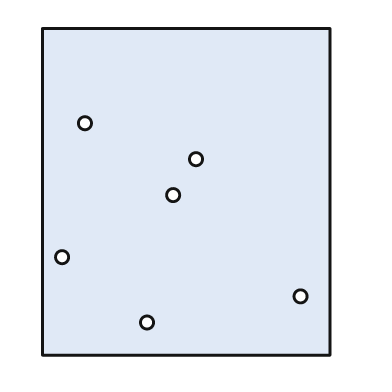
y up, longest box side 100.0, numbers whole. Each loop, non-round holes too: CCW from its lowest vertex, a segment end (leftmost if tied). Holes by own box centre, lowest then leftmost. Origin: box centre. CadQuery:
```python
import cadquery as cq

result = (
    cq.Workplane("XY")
    .moveTo(-44.0, -50.0)
    .lineTo(44.0, -50.0)
    .lineTo(44.0, 50.0)
    .lineTo(-44.0, 50.0)
    .close()
    .moveTo(-12.0, -40.0)
    .circle(2.0)
    .moveTo(35.0, -32.0)
    .circle(2.0)
    .moveTo(-38.0, -20.0)
    .circle(2.0)
    .moveTo(-4.0, -1.0)
    .circle(2.0)
    .moveTo(3.0, 10.0)
    .circle(2.0)
    .moveTo(-31.0, 21.0)
    .circle(2.0)
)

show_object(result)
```